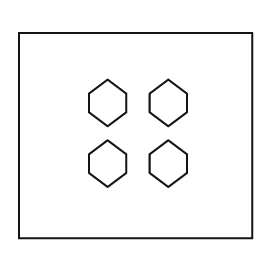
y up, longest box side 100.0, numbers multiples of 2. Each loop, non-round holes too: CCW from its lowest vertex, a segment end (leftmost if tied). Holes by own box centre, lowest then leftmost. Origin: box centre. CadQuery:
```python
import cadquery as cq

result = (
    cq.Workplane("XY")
    .moveTo(-50.0, -44.0)
    .lineTo(50.0, -44.0)
    .lineTo(50.0, 44.0)
    .lineTo(-50.0, 44.0)
    .close()
    .moveTo(-12.0, -22.0)
    .lineTo(-4.0, -16.0)
    .lineTo(-4.0, -8.0)
    .lineTo(-12.0, -2.0)
    .lineTo(-20.0, -8.0)
    .lineTo(-20.0, -16.0)
    .close()
    .moveTo(14.0, -22.0)
    .lineTo(22.0, -16.0)
    .lineTo(22.0, -8.0)
    .lineTo(14.0, -2.0)
    .lineTo(6.0, -8.0)
    .lineTo(6.0, -16.0)
    .close()
    .moveTo(-12.0, 4.0)
    .lineTo(-4.0, 10.0)
    .lineTo(-4.0, 18.0)
    .lineTo(-12.0, 24.0)
    .lineTo(-20.0, 18.0)
    .lineTo(-20.0, 10.0)
    .close()
    .moveTo(14.0, 4.0)
    .lineTo(22.0, 10.0)
    .lineTo(22.0, 18.0)
    .lineTo(14.0, 24.0)
    .lineTo(6.0, 18.0)
    .lineTo(6.0, 10.0)
    .close()
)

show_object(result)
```